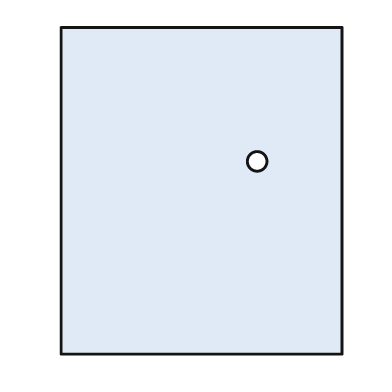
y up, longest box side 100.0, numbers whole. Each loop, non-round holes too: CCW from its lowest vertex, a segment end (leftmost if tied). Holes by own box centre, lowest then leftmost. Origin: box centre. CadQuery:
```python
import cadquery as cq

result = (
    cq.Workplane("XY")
    .moveTo(-43.0, -50.0)
    .lineTo(43.0, -50.0)
    .lineTo(43.0, 50.0)
    .lineTo(-43.0, 50.0)
    .close()
    .moveTo(17.0, 9.0)
    .circle(3.0)
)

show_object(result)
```